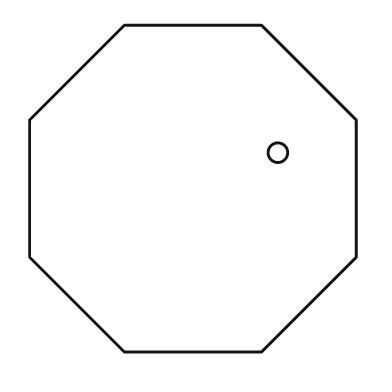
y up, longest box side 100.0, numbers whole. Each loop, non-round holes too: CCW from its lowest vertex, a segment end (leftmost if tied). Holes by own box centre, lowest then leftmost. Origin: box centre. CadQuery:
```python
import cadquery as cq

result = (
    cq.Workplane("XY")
    .moveTo(-21.0, -50.0)
    .lineTo(21.0, -50.0)
    .lineTo(50.0, -21.0)
    .lineTo(50.0, 21.0)
    .lineTo(21.0, 50.0)
    .lineTo(-21.0, 50.0)
    .lineTo(-50.0, 21.0)
    .lineTo(-50.0, -21.0)
    .close()
    .moveTo(26.0, 11.0)
    .circle(3.0)
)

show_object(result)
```